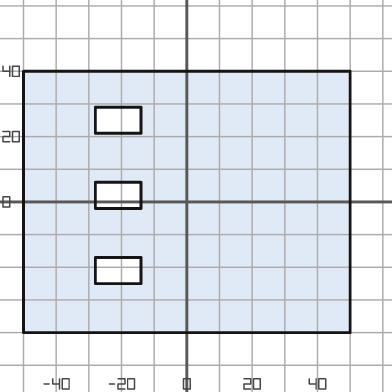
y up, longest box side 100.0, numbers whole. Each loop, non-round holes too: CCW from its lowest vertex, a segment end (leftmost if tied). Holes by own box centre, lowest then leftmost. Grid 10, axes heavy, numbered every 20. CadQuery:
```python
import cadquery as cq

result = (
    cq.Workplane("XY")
    .moveTo(-50.0, -40.0)
    .lineTo(50.0, -40.0)
    .lineTo(50.0, 40.0)
    .lineTo(-50.0, 40.0)
    .close()
    .moveTo(-28.0, -25.0)
    .lineTo(-14.0, -25.0)
    .lineTo(-14.0, -17.0)
    .lineTo(-28.0, -17.0)
    .close()
    .moveTo(-28.0, -2.0)
    .lineTo(-14.0, -2.0)
    .lineTo(-14.0, 6.0)
    .lineTo(-28.0, 6.0)
    .close()
    .moveTo(-28.0, 21.0)
    .lineTo(-14.0, 21.0)
    .lineTo(-14.0, 29.0)
    .lineTo(-28.0, 29.0)
    .close()
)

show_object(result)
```